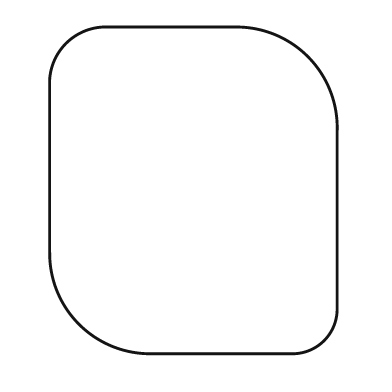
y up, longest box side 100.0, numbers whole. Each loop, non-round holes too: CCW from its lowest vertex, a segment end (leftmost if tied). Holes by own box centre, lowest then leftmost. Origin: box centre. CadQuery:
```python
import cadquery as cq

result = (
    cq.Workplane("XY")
    .moveTo(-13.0, -50.0)
    .lineTo(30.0, -50.0)
    .threePointArc((40.0, -46.0), (44.0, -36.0))
    .lineTo(44.0, 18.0)
    .threePointArc((35.0, 41.0), (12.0, 50.0))
    .lineTo(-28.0, 50.0)
    .threePointArc((-39.0, 45.0), (-44.0, 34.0))
    .lineTo(-44.0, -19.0)
    .threePointArc((-35.0, -41.0), (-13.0, -50.0))
    .close()
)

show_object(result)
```